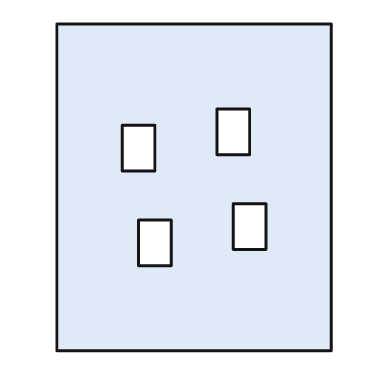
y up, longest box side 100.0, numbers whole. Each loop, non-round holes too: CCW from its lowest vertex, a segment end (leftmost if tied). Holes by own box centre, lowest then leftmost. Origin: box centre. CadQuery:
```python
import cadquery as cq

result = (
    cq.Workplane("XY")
    .moveTo(-42.0, -50.0)
    .lineTo(42.0, -50.0)
    .lineTo(42.0, 50.0)
    .lineTo(-42.0, 50.0)
    .close()
    .moveTo(-17.0, -24.0)
    .lineTo(-7.0, -24.0)
    .lineTo(-7.0, -10.0)
    .lineTo(-17.0, -10.0)
    .close()
    .moveTo(12.0, -19.0)
    .lineTo(22.0, -19.0)
    .lineTo(22.0, -5.0)
    .lineTo(12.0, -5.0)
    .close()
    .moveTo(-22.0, 5.0)
    .lineTo(-12.0, 5.0)
    .lineTo(-12.0, 19.0)
    .lineTo(-22.0, 19.0)
    .close()
    .moveTo(7.0, 10.0)
    .lineTo(17.0, 10.0)
    .lineTo(17.0, 24.0)
    .lineTo(7.0, 24.0)
    .close()
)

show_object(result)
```